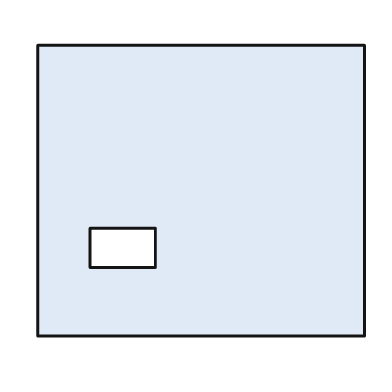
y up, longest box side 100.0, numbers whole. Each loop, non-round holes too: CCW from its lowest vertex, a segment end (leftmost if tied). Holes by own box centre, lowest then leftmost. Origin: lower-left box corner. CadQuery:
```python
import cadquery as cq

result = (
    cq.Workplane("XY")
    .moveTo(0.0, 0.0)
    .lineTo(100.0, 0.0)
    .lineTo(100.0, 89.0)
    .lineTo(0.0, 89.0)
    .close()
    .moveTo(16.0, 21.0)
    .lineTo(36.0, 21.0)
    .lineTo(36.0, 33.0)
    .lineTo(16.0, 33.0)
    .close()
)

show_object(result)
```